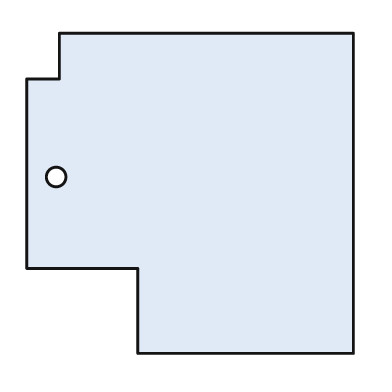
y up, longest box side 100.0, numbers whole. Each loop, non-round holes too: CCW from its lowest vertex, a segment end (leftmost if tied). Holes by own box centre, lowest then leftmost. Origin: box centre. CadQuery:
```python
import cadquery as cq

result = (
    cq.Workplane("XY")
    .moveTo(-16.0, -49.0)
    .lineTo(50.0, -49.0)
    .lineTo(50.0, 49.0)
    .lineTo(-40.0, 49.0)
    .lineTo(-40.0, 35.0)
    .lineTo(-50.0, 35.0)
    .lineTo(-50.0, -23.0)
    .lineTo(-16.0, -23.0)
    .close()
    .moveTo(-41.0, 5.0)
    .circle(3.0)
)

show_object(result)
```